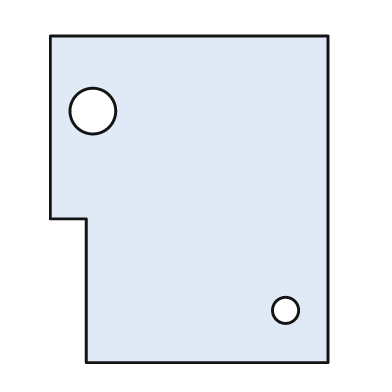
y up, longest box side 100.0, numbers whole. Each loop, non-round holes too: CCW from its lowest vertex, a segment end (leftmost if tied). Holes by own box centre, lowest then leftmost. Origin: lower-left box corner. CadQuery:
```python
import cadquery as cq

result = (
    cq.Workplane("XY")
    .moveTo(11.0, 0.0)
    .lineTo(85.0, 0.0)
    .lineTo(85.0, 100.0)
    .lineTo(0.0, 100.0)
    .lineTo(0.0, 44.0)
    .lineTo(11.0, 44.0)
    .close()
    .moveTo(72.0, 16.0)
    .circle(4.0)
    .moveTo(13.0, 77.0)
    .circle(7.0)
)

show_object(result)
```